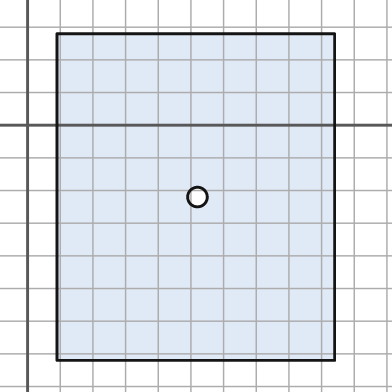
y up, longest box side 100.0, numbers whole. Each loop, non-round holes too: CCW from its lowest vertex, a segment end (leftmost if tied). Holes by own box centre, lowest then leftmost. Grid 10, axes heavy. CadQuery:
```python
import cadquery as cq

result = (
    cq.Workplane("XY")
    .moveTo(9.0, -72.0)
    .lineTo(94.0, -72.0)
    .lineTo(94.0, 28.0)
    .lineTo(9.0, 28.0)
    .close()
    .moveTo(52.0, -22.0)
    .circle(3.0)
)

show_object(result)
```